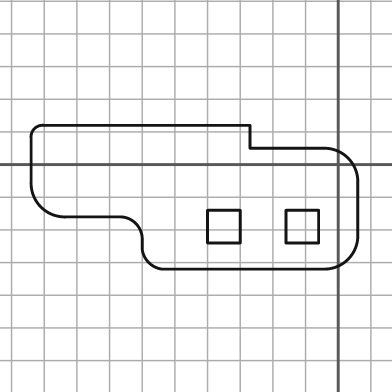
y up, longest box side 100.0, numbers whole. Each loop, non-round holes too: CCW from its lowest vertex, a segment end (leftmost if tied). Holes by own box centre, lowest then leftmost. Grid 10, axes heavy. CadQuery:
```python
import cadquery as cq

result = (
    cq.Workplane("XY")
    .moveTo(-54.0, -32.0)
    .lineTo(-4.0, -32.0)
    .threePointArc((3.0, -29.0), (6.0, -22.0))
    .lineTo(6.0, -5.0)
    .threePointArc((3.0, 2.0), (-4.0, 5.0))
    .lineTo(-27.0, 5.0)
    .lineTo(-27.0, 12.0)
    .lineTo(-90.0, 12.0)
    .threePointArc((-93.0, 11.0), (-94.0, 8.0))
    .lineTo(-94.0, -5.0)
    .threePointArc((-91.0, -13.0), (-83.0, -16.0))
    .lineTo(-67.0, -16.0)
    .threePointArc((-62.0, -18.0), (-60.0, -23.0))
    .lineTo(-60.0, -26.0)
    .threePointArc((-58.0, -30.0), (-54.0, -32.0))
    .close()
    .moveTo(-40.0, -24.0)
    .lineTo(-30.0, -24.0)
    .lineTo(-30.0, -14.0)
    .lineTo(-40.0, -14.0)
    .close()
    .moveTo(-16.0, -24.0)
    .lineTo(-6.0, -24.0)
    .lineTo(-6.0, -14.0)
    .lineTo(-16.0, -14.0)
    .close()
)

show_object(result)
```